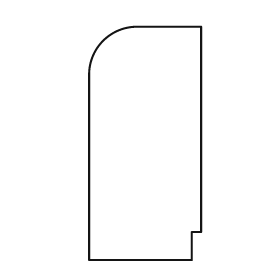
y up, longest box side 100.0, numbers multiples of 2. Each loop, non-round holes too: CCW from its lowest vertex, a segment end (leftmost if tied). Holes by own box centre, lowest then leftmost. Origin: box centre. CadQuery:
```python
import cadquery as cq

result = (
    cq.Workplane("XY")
    .moveTo(-24.0, -50.0)
    .lineTo(20.0, -50.0)
    .lineTo(20.0, -38.0)
    .lineTo(24.0, -38.0)
    .lineTo(24.0, 50.0)
    .lineTo(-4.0, 50.0)
    .threePointArc((-18.0, 44.0), (-24.0, 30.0))
    .close()
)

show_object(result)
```